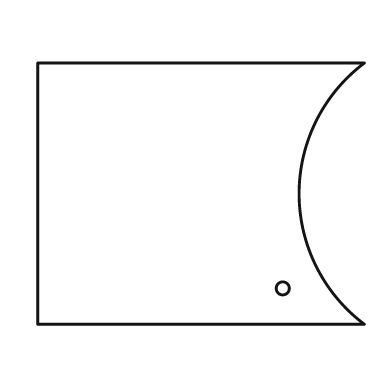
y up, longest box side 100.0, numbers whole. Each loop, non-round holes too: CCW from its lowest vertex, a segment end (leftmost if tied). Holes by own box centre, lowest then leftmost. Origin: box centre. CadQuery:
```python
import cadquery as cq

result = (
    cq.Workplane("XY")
    .moveTo(-50.0, -40.0)
    .lineTo(50.0, -40.0)
    .threePointArc((30.0, 0.0), (50.0, 40.0))
    .lineTo(-50.0, 40.0)
    .close()
    .moveTo(25.0, -29.0)
    .circle(2.0)
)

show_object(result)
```